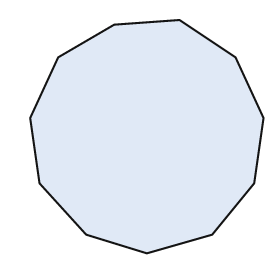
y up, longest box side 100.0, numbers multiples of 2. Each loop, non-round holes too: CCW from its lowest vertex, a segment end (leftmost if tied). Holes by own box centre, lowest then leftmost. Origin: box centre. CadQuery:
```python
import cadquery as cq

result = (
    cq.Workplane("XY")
    .moveTo(0.0, -50.0)
    .lineTo(28.0, -42.0)
    .lineTo(46.0, -20.0)
    .lineTo(50.0, 8.0)
    .lineTo(38.0, 34.0)
    .lineTo(14.0, 50.0)
    .lineTo(-14.0, 48.0)
    .lineTo(-38.0, 34.0)
    .lineTo(-50.0, 8.0)
    .lineTo(-46.0, -20.0)
    .lineTo(-26.0, -42.0)
    .close()
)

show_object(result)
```